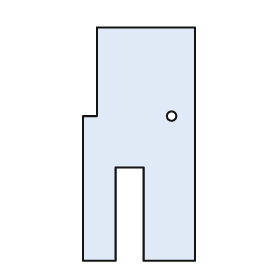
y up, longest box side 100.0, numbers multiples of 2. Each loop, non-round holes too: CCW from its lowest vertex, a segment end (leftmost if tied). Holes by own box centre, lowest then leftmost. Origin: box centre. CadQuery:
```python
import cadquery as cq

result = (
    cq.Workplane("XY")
    .moveTo(-24.0, -50.0)
    .lineTo(-10.0, -50.0)
    .lineTo(-10.0, -10.0)
    .lineTo(2.0, -10.0)
    .lineTo(2.0, -50.0)
    .lineTo(24.0, -50.0)
    .lineTo(24.0, 50.0)
    .lineTo(-18.0, 50.0)
    .lineTo(-18.0, 12.0)
    .lineTo(-24.0, 12.0)
    .close()
    .moveTo(14.0, 12.0)
    .circle(2.0)
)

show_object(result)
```